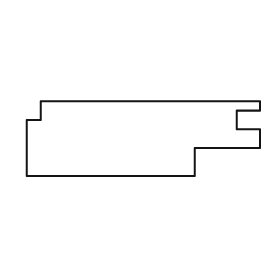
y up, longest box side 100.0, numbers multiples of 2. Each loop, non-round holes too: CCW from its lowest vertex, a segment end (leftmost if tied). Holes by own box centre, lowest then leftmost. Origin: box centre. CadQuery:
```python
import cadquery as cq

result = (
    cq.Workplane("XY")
    .moveTo(-50.0, -16.0)
    .lineTo(22.0, -16.0)
    .lineTo(22.0, -4.0)
    .lineTo(50.0, -4.0)
    .lineTo(50.0, 4.0)
    .lineTo(40.0, 4.0)
    .lineTo(40.0, 12.0)
    .lineTo(50.0, 12.0)
    .lineTo(50.0, 16.0)
    .lineTo(-44.0, 16.0)
    .lineTo(-44.0, 8.0)
    .lineTo(-50.0, 8.0)
    .close()
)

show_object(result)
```